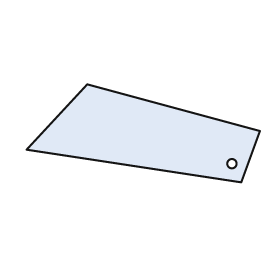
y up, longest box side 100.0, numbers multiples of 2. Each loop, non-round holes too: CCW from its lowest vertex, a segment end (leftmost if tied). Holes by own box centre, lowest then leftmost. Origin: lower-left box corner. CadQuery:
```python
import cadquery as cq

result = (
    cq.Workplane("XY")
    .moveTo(92.0, 0.0)
    .lineTo(100.0, 22.0)
    .lineTo(26.0, 42.0)
    .lineTo(0.0, 14.0)
    .close()
    .moveTo(88.0, 8.0)
    .circle(2.0)
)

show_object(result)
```